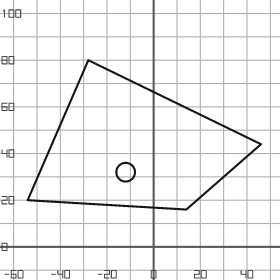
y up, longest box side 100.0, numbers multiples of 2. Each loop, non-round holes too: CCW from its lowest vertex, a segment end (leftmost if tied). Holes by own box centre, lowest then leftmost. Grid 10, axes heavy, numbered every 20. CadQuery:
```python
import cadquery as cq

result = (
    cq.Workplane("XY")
    .moveTo(14.0, 16.0)
    .lineTo(46.0, 44.0)
    .lineTo(-28.0, 80.0)
    .lineTo(-54.0, 20.0)
    .close()
    .moveTo(-12.0, 32.0)
    .circle(4.0)
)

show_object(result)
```